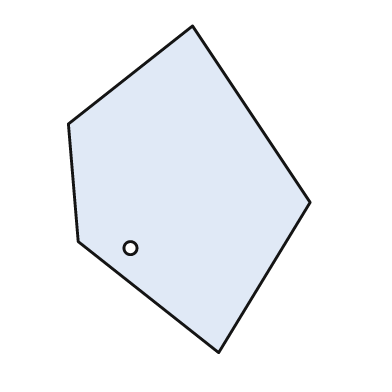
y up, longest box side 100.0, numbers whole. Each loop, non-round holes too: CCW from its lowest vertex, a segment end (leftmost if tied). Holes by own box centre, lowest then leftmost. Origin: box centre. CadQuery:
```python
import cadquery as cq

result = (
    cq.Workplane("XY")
    .moveTo(9.0, -50.0)
    .lineTo(37.0, -4.0)
    .lineTo(1.0, 50.0)
    .lineTo(-37.0, 20.0)
    .lineTo(-34.0, -16.0)
    .close()
    .moveTo(-18.0, -18.0)
    .circle(2.0)
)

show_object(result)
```